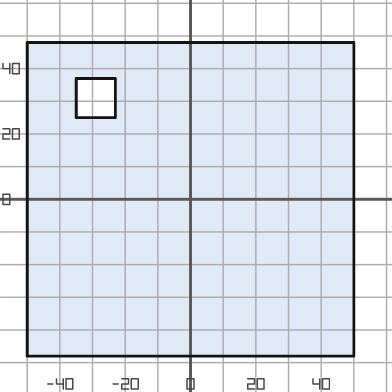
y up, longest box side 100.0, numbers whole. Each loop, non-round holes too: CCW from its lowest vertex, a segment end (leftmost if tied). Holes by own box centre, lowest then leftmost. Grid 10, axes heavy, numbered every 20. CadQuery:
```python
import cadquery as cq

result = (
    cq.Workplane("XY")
    .moveTo(-50.0, -48.0)
    .lineTo(50.0, -48.0)
    .lineTo(50.0, 48.0)
    .lineTo(-50.0, 48.0)
    .close()
    .moveTo(-35.0, 25.0)
    .lineTo(-23.0, 25.0)
    .lineTo(-23.0, 37.0)
    .lineTo(-35.0, 37.0)
    .close()
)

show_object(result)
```